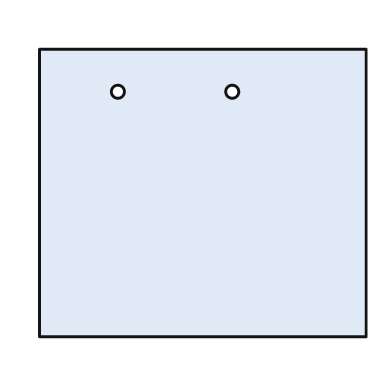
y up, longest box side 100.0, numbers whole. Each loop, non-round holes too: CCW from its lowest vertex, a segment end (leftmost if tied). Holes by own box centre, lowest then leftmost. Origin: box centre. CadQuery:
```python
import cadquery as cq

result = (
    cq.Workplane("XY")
    .moveTo(-50.0, -44.0)
    .lineTo(50.0, -44.0)
    .lineTo(50.0, 44.0)
    .lineTo(-50.0, 44.0)
    .close()
    .moveTo(-26.0, 31.0)
    .circle(2.0)
    .moveTo(9.0, 31.0)
    .circle(2.0)
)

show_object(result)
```